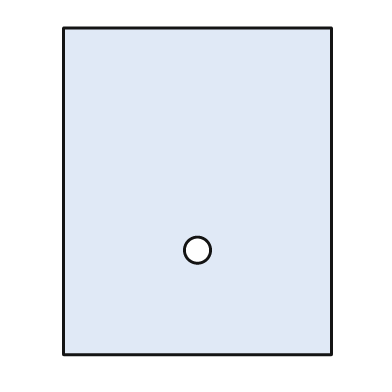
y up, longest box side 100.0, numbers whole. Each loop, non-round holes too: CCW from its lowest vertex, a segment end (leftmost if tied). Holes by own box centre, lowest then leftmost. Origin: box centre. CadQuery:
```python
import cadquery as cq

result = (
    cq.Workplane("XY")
    .moveTo(-41.0, -50.0)
    .lineTo(41.0, -50.0)
    .lineTo(41.0, 50.0)
    .lineTo(-41.0, 50.0)
    .close()
    .moveTo(0.0, -18.0)
    .circle(4.0)
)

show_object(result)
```